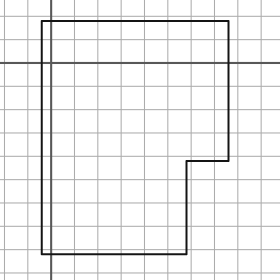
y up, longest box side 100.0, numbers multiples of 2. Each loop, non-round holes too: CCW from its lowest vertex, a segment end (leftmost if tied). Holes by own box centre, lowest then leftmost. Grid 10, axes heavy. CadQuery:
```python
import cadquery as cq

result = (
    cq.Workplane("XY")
    .moveTo(-4.0, -82.0)
    .lineTo(58.0, -82.0)
    .lineTo(58.0, -42.0)
    .lineTo(76.0, -42.0)
    .lineTo(76.0, 18.0)
    .lineTo(-4.0, 18.0)
    .close()
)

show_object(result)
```